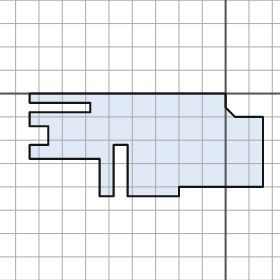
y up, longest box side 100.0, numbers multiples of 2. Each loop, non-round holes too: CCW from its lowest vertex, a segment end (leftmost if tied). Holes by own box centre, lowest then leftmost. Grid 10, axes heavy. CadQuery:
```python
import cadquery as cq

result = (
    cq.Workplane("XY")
    .moveTo(-54.0, -44.0)
    .lineTo(-48.0, -44.0)
    .lineTo(-48.0, -22.0)
    .lineTo(-42.0, -22.0)
    .lineTo(-42.0, -44.0)
    .lineTo(-20.0, -44.0)
    .lineTo(-20.0, -40.0)
    .lineTo(16.0, -40.0)
    .lineTo(16.0, -10.0)
    .lineTo(4.0, -10.0)
    .lineTo(0.0, -6.0)
    .lineTo(0.0, 0.0)
    .lineTo(-84.0, 0.0)
    .lineTo(-84.0, -4.0)
    .lineTo(-58.0, -4.0)
    .lineTo(-58.0, -8.0)
    .lineTo(-84.0, -8.0)
    .lineTo(-84.0, -14.0)
    .lineTo(-76.0, -14.0)
    .lineTo(-76.0, -22.0)
    .lineTo(-84.0, -22.0)
    .lineTo(-84.0, -28.0)
    .lineTo(-54.0, -28.0)
    .close()
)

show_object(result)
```